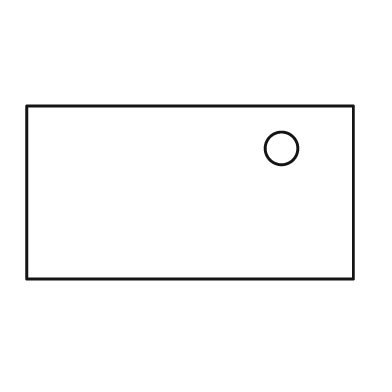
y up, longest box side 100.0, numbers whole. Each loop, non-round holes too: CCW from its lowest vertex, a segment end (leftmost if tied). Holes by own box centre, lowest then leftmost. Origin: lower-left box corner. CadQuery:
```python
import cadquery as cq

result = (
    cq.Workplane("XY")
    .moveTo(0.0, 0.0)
    .lineTo(100.0, 0.0)
    .lineTo(100.0, 53.0)
    .lineTo(0.0, 53.0)
    .close()
    .moveTo(78.0, 40.0)
    .circle(5.0)
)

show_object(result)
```